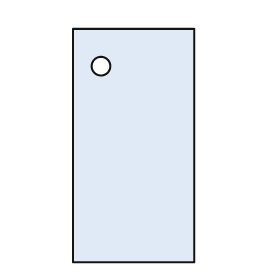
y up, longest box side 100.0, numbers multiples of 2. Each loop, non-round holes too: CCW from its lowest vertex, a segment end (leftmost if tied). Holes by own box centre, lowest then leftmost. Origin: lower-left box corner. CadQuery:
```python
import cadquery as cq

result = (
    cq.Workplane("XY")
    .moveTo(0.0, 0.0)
    .lineTo(52.0, 0.0)
    .lineTo(52.0, 100.0)
    .lineTo(0.0, 100.0)
    .close()
    .moveTo(12.0, 84.0)
    .circle(4.0)
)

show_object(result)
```